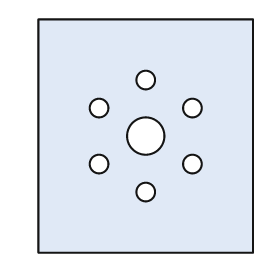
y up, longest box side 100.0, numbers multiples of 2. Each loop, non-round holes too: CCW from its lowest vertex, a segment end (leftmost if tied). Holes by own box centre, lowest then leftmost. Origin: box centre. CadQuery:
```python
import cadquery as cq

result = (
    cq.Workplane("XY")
    .moveTo(-46.0, -50.0)
    .lineTo(46.0, -50.0)
    .lineTo(46.0, 50.0)
    .lineTo(-46.0, 50.0)
    .close()
    .moveTo(0.0, -24.0)
    .circle(4.0)
    .moveTo(-20.0, -12.0)
    .circle(4.0)
    .moveTo(20.0, -12.0)
    .circle(4.0)
    .moveTo(0.0, 0.0)
    .circle(8.0)
    .moveTo(-20.0, 12.0)
    .circle(4.0)
    .moveTo(20.0, 12.0)
    .circle(4.0)
    .moveTo(0.0, 24.0)
    .circle(4.0)
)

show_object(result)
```